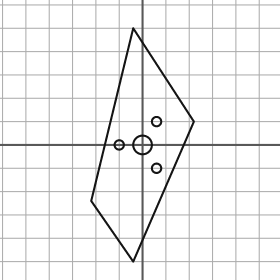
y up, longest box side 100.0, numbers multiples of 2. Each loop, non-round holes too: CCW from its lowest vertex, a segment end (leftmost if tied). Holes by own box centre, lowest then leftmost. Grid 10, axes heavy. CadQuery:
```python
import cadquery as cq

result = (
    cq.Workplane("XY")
    .moveTo(-4.0, -50.0)
    .lineTo(22.0, 10.0)
    .lineTo(-4.0, 50.0)
    .lineTo(-22.0, -24.0)
    .close()
    .moveTo(6.0, -10.0)
    .circle(2.0)
    .moveTo(-10.0, 0.0)
    .circle(2.0)
    .moveTo(0.0, 0.0)
    .circle(4.0)
    .moveTo(6.0, 10.0)
    .circle(2.0)
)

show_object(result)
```